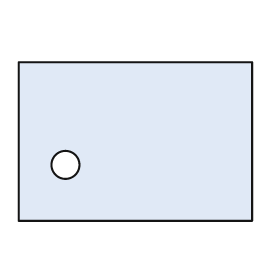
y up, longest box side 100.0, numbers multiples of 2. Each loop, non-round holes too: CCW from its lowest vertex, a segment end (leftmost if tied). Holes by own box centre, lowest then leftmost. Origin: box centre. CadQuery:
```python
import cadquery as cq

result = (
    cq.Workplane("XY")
    .moveTo(-50.0, -34.0)
    .lineTo(50.0, -34.0)
    .lineTo(50.0, 34.0)
    .lineTo(-50.0, 34.0)
    .close()
    .moveTo(-30.0, -10.0)
    .circle(6.0)
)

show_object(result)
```